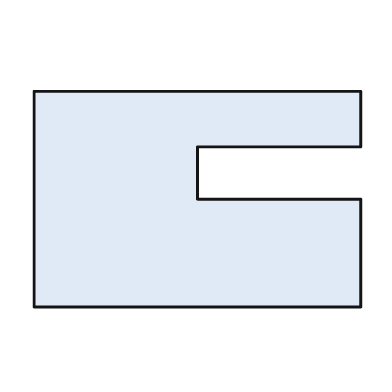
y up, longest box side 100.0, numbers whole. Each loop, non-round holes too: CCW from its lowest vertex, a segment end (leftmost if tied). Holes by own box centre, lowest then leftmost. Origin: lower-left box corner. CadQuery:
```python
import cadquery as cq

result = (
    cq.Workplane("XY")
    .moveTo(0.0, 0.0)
    .lineTo(100.0, 0.0)
    .lineTo(100.0, 33.0)
    .lineTo(50.0, 33.0)
    .lineTo(50.0, 49.0)
    .lineTo(100.0, 49.0)
    .lineTo(100.0, 66.0)
    .lineTo(0.0, 66.0)
    .close()
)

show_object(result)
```